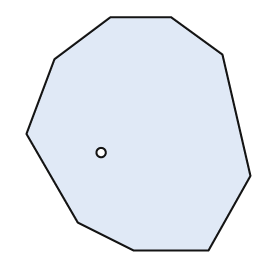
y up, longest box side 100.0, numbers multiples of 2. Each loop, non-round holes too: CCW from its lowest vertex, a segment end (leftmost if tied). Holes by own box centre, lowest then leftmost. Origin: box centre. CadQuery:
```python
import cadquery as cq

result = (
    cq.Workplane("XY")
    .moveTo(-2.0, -50.0)
    .lineTo(30.0, -50.0)
    .lineTo(48.0, -18.0)
    .lineTo(36.0, 34.0)
    .lineTo(14.0, 50.0)
    .lineTo(-12.0, 50.0)
    .lineTo(-36.0, 32.0)
    .lineTo(-48.0, 0.0)
    .lineTo(-26.0, -38.0)
    .close()
    .moveTo(-16.0, -8.0)
    .circle(2.0)
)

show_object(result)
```